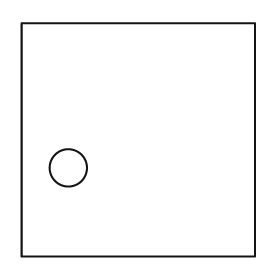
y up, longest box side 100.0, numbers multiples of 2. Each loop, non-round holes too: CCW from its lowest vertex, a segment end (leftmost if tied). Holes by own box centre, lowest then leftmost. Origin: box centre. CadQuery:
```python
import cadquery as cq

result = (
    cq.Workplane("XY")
    .moveTo(-50.0, -50.0)
    .lineTo(50.0, -50.0)
    .lineTo(50.0, 50.0)
    .lineTo(-50.0, 50.0)
    .close()
    .moveTo(-30.0, -12.0)
    .circle(8.0)
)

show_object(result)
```